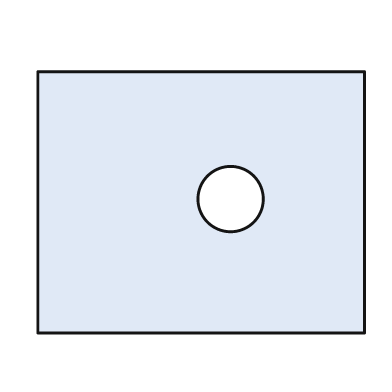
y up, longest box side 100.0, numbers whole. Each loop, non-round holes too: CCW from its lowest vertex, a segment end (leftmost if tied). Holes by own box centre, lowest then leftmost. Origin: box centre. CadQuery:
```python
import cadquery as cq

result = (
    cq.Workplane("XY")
    .moveTo(-50.0, -40.0)
    .lineTo(50.0, -40.0)
    .lineTo(50.0, 40.0)
    .lineTo(-50.0, 40.0)
    .close()
    .moveTo(9.0, 1.0)
    .circle(10.0)
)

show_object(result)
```